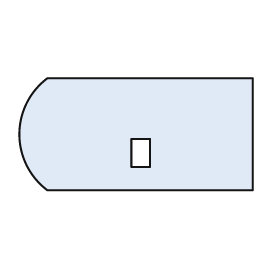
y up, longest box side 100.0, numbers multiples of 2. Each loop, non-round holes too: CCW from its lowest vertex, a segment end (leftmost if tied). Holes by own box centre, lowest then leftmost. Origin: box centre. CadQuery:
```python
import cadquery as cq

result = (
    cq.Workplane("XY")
    .moveTo(-38.0, -24.0)
    .lineTo(50.0, -24.0)
    .lineTo(50.0, 24.0)
    .lineTo(-38.0, 24.0)
    .threePointArc((-50.0, 0.0), (-38.0, -24.0))
    .close()
    .moveTo(-2.0, -14.0)
    .lineTo(6.0, -14.0)
    .lineTo(6.0, -2.0)
    .lineTo(-2.0, -2.0)
    .close()
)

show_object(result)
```